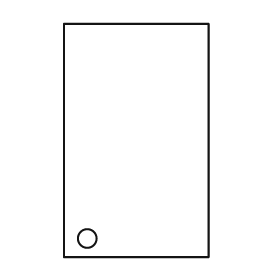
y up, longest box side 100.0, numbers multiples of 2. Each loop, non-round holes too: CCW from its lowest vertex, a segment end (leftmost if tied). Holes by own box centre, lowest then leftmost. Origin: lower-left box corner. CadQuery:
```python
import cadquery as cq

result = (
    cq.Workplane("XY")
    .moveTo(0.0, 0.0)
    .lineTo(62.0, 0.0)
    .lineTo(62.0, 100.0)
    .lineTo(0.0, 100.0)
    .close()
    .moveTo(10.0, 8.0)
    .circle(4.0)
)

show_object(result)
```